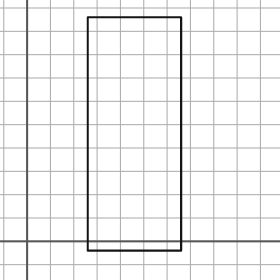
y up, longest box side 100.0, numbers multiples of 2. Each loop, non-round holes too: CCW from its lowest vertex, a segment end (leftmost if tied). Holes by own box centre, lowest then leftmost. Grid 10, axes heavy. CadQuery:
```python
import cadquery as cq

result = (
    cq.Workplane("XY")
    .moveTo(26.0, -4.0)
    .lineTo(66.0, -4.0)
    .lineTo(66.0, 96.0)
    .lineTo(26.0, 96.0)
    .close()
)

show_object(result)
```